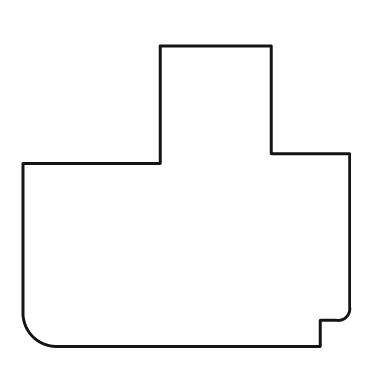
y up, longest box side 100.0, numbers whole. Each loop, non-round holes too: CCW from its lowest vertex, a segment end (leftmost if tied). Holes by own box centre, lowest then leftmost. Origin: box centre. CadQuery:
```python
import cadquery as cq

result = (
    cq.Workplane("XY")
    .moveTo(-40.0, -46.0)
    .lineTo(41.0, -46.0)
    .lineTo(41.0, -38.0)
    .lineTo(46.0, -38.0)
    .threePointArc((49.0, -37.0), (50.0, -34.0))
    .lineTo(50.0, 13.0)
    .lineTo(26.0, 13.0)
    .lineTo(26.0, 46.0)
    .lineTo(-8.0, 46.0)
    .lineTo(-8.0, 10.0)
    .lineTo(-50.0, 10.0)
    .lineTo(-50.0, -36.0)
    .threePointArc((-47.0, -43.0), (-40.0, -46.0))
    .close()
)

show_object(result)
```